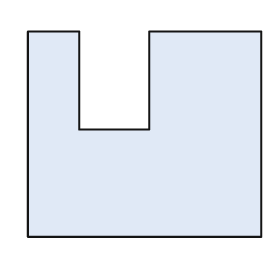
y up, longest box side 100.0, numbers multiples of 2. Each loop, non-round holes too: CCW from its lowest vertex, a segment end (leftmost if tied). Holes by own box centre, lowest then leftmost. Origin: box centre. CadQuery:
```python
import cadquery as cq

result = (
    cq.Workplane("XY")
    .moveTo(-50.0, -44.0)
    .lineTo(50.0, -44.0)
    .lineTo(50.0, 44.0)
    .lineTo(2.0, 44.0)
    .lineTo(2.0, 2.0)
    .lineTo(-28.0, 2.0)
    .lineTo(-28.0, 44.0)
    .lineTo(-50.0, 44.0)
    .close()
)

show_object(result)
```